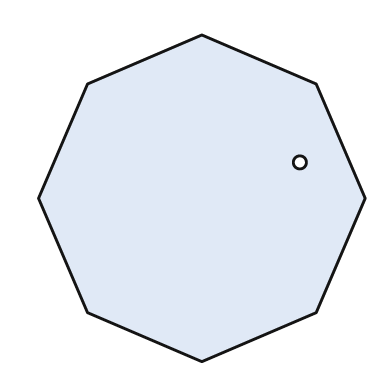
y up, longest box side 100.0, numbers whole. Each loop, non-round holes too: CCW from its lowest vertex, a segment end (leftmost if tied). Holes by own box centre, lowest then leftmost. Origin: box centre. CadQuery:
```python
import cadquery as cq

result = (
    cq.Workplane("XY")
    .moveTo(0.0, -50.0)
    .lineTo(35.0, -35.0)
    .lineTo(50.0, 0.0)
    .lineTo(35.0, 35.0)
    .lineTo(0.0, 50.0)
    .lineTo(-35.0, 35.0)
    .lineTo(-50.0, 0.0)
    .lineTo(-35.0, -35.0)
    .close()
    .moveTo(30.0, 11.0)
    .circle(2.0)
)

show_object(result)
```